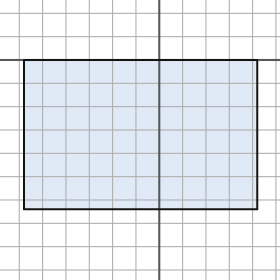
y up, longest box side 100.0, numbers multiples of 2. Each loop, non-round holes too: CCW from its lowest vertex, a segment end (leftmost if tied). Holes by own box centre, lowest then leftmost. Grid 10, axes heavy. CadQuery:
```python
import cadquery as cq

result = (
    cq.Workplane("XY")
    .moveTo(-58.0, -64.0)
    .lineTo(42.0, -64.0)
    .lineTo(42.0, 0.0)
    .lineTo(-58.0, 0.0)
    .close()
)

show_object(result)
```